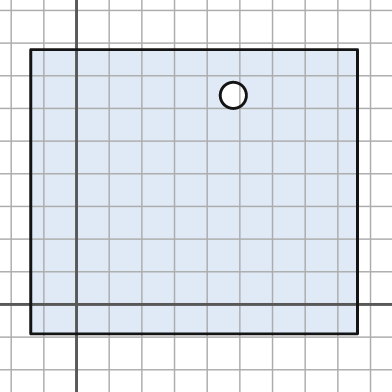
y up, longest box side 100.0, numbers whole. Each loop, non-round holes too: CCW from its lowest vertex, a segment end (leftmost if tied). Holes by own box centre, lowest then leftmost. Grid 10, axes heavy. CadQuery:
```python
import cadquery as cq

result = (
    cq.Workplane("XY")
    .moveTo(-14.0, -9.0)
    .lineTo(86.0, -9.0)
    .lineTo(86.0, 78.0)
    .lineTo(-14.0, 78.0)
    .close()
    .moveTo(48.0, 64.0)
    .circle(4.0)
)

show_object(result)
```